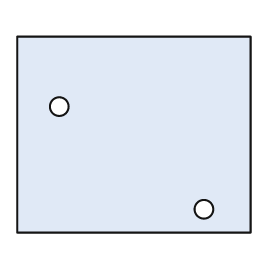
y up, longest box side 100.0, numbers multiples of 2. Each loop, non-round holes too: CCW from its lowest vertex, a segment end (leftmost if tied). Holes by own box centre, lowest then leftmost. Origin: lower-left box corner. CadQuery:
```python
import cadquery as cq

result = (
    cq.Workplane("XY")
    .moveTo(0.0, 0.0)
    .lineTo(100.0, 0.0)
    .lineTo(100.0, 84.0)
    .lineTo(0.0, 84.0)
    .close()
    .moveTo(80.0, 10.0)
    .circle(4.0)
    .moveTo(18.0, 54.0)
    .circle(4.0)
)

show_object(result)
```